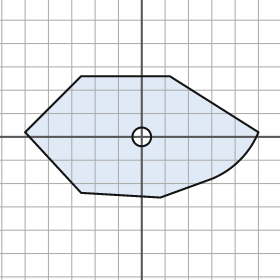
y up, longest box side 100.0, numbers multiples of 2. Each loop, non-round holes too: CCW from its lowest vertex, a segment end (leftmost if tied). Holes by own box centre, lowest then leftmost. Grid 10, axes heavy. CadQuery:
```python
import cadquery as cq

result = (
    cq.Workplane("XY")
    .moveTo(8.0, -26.0)
    .lineTo(30.0, -18.0)
    .threePointArc((42.0, -10.0), (50.0, 2.0))
    .lineTo(12.0, 26.0)
    .lineTo(-26.0, 26.0)
    .lineTo(-50.0, 2.0)
    .lineTo(-26.0, -24.0)
    .close()
    .moveTo(0.0, 0.0)
    .circle(4.0)
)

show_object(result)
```